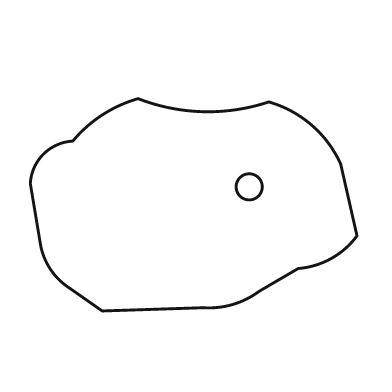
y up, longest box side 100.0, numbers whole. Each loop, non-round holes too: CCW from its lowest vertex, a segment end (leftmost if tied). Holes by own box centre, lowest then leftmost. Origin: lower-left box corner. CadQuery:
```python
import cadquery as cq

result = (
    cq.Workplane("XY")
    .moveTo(22.0, 0.0)
    .lineTo(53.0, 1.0)
    .threePointArc((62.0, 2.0), (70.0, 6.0))
    .lineTo(82.0, 13.0)
    .threePointArc((92.0, 16.0), (100.0, 23.0))
    .lineTo(95.0, 45.0)
    .threePointArc((86.0, 57.0), (73.0, 64.0))
    .threePointArc((53.0, 61.0), (33.0, 65.0))
    .threePointArc((22.0, 60.0), (13.0, 52.0))
    .threePointArc((4.0, 48.0), (0.0, 39.0))
    .lineTo(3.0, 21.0)
    .threePointArc((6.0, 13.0), (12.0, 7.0))
    .close()
    .moveTo(67.0, 38.0)
    .circle(4.0)
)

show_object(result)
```